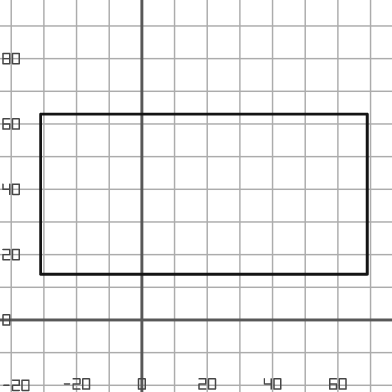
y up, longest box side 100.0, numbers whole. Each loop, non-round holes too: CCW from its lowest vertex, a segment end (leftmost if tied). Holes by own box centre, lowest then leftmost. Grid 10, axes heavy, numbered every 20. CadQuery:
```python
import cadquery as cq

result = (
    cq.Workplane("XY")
    .moveTo(-31.0, 14.0)
    .lineTo(69.0, 14.0)
    .lineTo(69.0, 63.0)
    .lineTo(-31.0, 63.0)
    .close()
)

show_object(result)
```